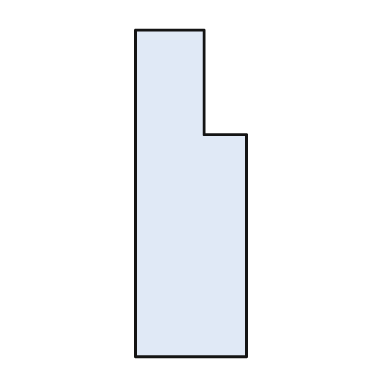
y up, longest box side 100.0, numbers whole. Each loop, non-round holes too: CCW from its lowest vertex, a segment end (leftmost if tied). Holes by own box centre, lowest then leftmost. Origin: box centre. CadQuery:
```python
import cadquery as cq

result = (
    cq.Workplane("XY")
    .moveTo(-17.0, -50.0)
    .lineTo(17.0, -50.0)
    .lineTo(17.0, 18.0)
    .lineTo(4.0, 18.0)
    .lineTo(4.0, 50.0)
    .lineTo(-17.0, 50.0)
    .close()
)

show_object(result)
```